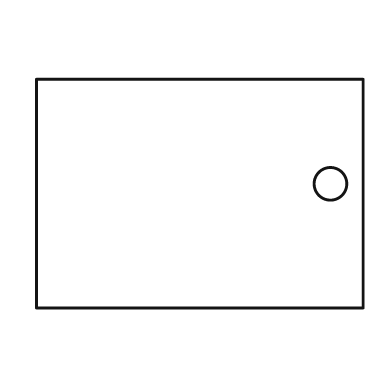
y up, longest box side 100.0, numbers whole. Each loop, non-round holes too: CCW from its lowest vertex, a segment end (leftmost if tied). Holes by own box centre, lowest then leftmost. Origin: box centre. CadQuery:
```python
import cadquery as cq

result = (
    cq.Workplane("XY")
    .moveTo(-50.0, -35.0)
    .lineTo(50.0, -35.0)
    .lineTo(50.0, 35.0)
    .lineTo(-50.0, 35.0)
    .close()
    .moveTo(40.0, 3.0)
    .circle(5.0)
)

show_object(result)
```